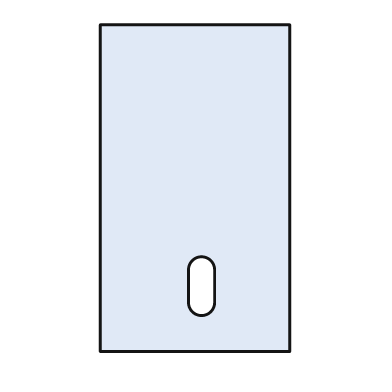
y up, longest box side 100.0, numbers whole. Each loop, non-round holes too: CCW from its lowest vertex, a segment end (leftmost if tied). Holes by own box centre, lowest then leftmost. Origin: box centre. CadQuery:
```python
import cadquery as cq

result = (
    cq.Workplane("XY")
    .moveTo(-29.0, -50.0)
    .lineTo(29.0, -50.0)
    .lineTo(29.0, 50.0)
    .lineTo(-29.0, 50.0)
    .close()
    .moveTo(-2.0, -35.0)
    .threePointArc((2.0, -39.0), (6.0, -35.0))
    .lineTo(6.0, -25.0)
    .threePointArc((2.0, -21.0), (-2.0, -25.0))
    .close()
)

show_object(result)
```